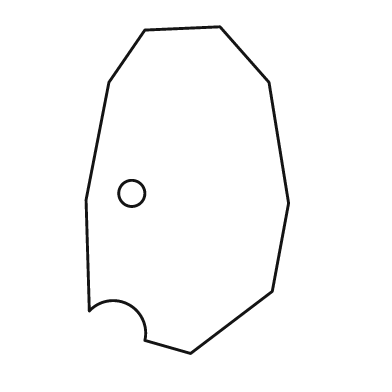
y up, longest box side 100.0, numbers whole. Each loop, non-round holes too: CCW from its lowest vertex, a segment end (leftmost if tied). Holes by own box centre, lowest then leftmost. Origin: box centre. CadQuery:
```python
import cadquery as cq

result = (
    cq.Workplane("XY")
    .moveTo(1.0, -50.0)
    .lineTo(26.0, -31.0)
    .lineTo(31.0, -4.0)
    .lineTo(25.0, 33.0)
    .lineTo(10.0, 50.0)
    .lineTo(-13.0, 49.0)
    .lineTo(-24.0, 33.0)
    .lineTo(-31.0, -3.0)
    .lineTo(-30.0, -37.0)
    .threePointArc((-18.0, -35.0), (-13.0, -46.0))
    .close()
    .moveTo(-17.0, -1.0)
    .circle(4.0)
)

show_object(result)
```